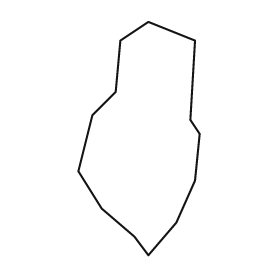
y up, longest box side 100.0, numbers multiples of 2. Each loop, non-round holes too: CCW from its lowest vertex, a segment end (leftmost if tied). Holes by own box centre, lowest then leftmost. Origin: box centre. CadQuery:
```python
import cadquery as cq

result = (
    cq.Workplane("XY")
    .moveTo(4.0, -50.0)
    .lineTo(16.0, -36.0)
    .lineTo(24.0, -18.0)
    .lineTo(26.0, 2.0)
    .lineTo(22.0, 8.0)
    .lineTo(24.0, 42.0)
    .lineTo(4.0, 50.0)
    .lineTo(-8.0, 42.0)
    .lineTo(-10.0, 20.0)
    .lineTo(-20.0, 10.0)
    .lineTo(-26.0, -14.0)
    .lineTo(-16.0, -30.0)
    .lineTo(-2.0, -42.0)
    .close()
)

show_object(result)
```